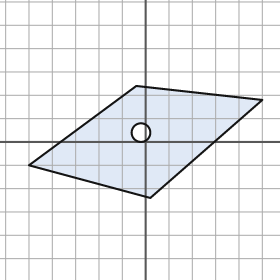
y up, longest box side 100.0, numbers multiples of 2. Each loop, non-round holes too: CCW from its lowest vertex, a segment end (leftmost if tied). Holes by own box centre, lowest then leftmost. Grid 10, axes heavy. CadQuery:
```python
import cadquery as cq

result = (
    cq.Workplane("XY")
    .moveTo(2.0, -24.0)
    .lineTo(50.0, 18.0)
    .lineTo(-4.0, 24.0)
    .lineTo(-50.0, -10.0)
    .close()
    .moveTo(-2.0, 4.0)
    .circle(4.0)
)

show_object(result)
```